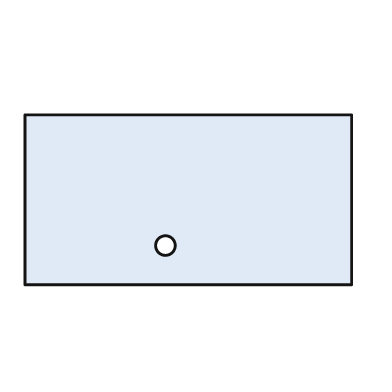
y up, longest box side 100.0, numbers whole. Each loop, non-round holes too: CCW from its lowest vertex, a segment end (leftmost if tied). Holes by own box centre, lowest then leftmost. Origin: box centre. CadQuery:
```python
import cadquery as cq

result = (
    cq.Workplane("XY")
    .moveTo(-50.0, -26.0)
    .lineTo(50.0, -26.0)
    .lineTo(50.0, 26.0)
    .lineTo(-50.0, 26.0)
    .close()
    .moveTo(-7.0, -14.0)
    .circle(3.0)
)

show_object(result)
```